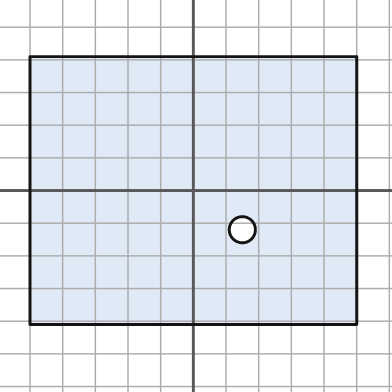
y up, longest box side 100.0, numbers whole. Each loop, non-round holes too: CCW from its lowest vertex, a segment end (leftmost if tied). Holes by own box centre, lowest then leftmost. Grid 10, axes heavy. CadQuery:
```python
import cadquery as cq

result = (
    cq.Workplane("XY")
    .moveTo(-50.0, -41.0)
    .lineTo(50.0, -41.0)
    .lineTo(50.0, 41.0)
    .lineTo(-50.0, 41.0)
    .close()
    .moveTo(15.0, -12.0)
    .circle(4.0)
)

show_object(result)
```